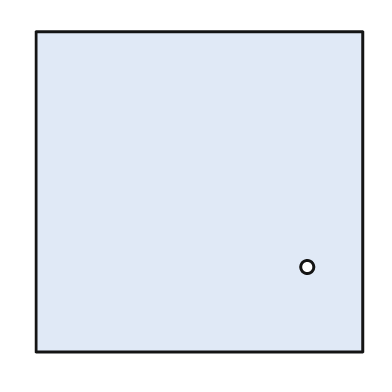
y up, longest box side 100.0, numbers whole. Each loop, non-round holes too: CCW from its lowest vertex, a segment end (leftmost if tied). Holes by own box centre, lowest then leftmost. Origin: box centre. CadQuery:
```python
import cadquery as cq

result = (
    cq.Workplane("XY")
    .moveTo(-50.0, -49.0)
    .lineTo(50.0, -49.0)
    .lineTo(50.0, 49.0)
    .lineTo(-50.0, 49.0)
    .close()
    .moveTo(33.0, -23.0)
    .circle(2.0)
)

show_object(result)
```